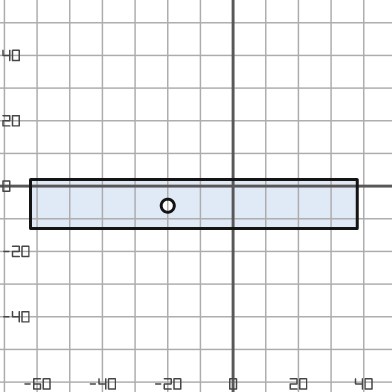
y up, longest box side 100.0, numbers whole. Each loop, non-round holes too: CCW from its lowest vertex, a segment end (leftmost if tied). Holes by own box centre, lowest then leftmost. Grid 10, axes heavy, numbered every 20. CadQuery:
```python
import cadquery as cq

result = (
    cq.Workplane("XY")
    .moveTo(-62.0, -13.0)
    .lineTo(38.0, -13.0)
    .lineTo(38.0, 2.0)
    .lineTo(-62.0, 2.0)
    .close()
    .moveTo(-20.0, -6.0)
    .circle(2.0)
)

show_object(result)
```